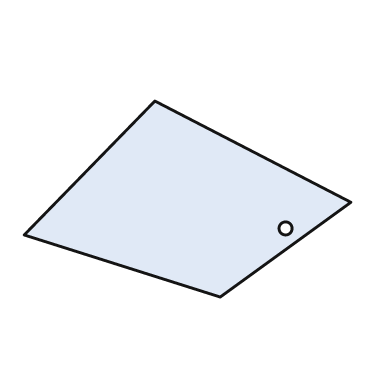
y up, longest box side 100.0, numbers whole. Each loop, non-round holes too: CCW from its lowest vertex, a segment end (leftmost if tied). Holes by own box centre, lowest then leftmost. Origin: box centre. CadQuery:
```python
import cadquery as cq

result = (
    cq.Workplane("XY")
    .moveTo(10.0, -30.0)
    .lineTo(50.0, -1.0)
    .lineTo(-10.0, 30.0)
    .lineTo(-50.0, -11.0)
    .close()
    .moveTo(30.0, -9.0)
    .circle(2.0)
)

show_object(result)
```